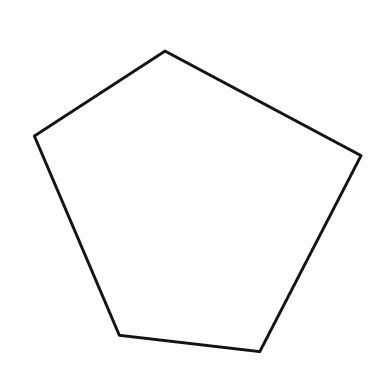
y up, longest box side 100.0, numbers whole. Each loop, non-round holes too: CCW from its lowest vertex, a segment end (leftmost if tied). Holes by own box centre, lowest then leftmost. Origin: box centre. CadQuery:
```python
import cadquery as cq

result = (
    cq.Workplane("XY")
    .moveTo(19.0, -46.0)
    .lineTo(50.0, 14.0)
    .lineTo(-10.0, 46.0)
    .lineTo(-50.0, 20.0)
    .lineTo(-24.0, -41.0)
    .close()
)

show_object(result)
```